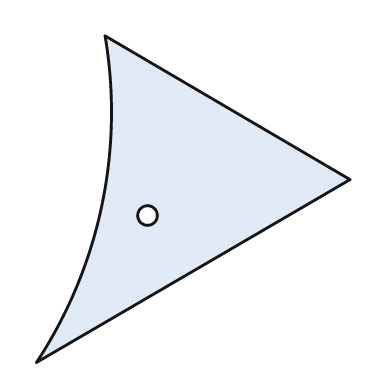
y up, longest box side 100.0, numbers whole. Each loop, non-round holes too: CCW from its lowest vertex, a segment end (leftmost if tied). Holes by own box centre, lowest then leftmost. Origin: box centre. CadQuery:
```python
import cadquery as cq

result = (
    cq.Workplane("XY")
    .moveTo(-48.0, -50.0)
    .lineTo(48.0, 6.0)
    .lineTo(-27.0, 50.0)
    .threePointArc((-28.0, -2.0), (-48.0, -50.0))
    .close()
    .moveTo(-14.0, -5.0)
    .circle(3.0)
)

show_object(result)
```